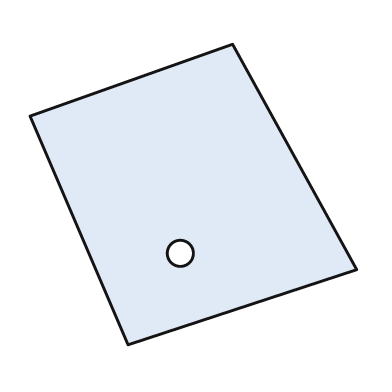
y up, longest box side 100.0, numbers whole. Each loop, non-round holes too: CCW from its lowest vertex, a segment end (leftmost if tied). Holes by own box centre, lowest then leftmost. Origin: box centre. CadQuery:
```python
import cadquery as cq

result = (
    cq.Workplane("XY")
    .moveTo(-20.0, -46.0)
    .lineTo(50.0, -23.0)
    .lineTo(12.0, 46.0)
    .lineTo(-50.0, 24.0)
    .close()
    .moveTo(-4.0, -18.0)
    .circle(4.0)
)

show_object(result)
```